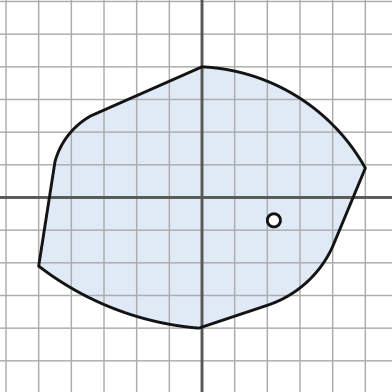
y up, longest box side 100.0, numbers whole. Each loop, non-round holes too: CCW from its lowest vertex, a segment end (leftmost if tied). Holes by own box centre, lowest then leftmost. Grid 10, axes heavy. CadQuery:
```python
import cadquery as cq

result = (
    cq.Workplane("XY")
    .moveTo(-1.0, -40.0)
    .lineTo(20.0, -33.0)
    .threePointArc((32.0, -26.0), (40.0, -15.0))
    .lineTo(50.0, 9.0)
    .threePointArc((29.0, 31.0), (0.0, 40.0))
    .lineTo(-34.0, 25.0)
    .threePointArc((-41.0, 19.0), (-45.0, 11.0))
    .lineTo(-50.0, -21.0)
    .threePointArc((-27.0, -34.0), (-1.0, -40.0))
    .close()
    .moveTo(22.0, -7.0)
    .circle(2.0)
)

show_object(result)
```